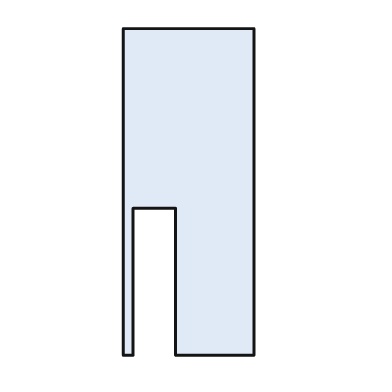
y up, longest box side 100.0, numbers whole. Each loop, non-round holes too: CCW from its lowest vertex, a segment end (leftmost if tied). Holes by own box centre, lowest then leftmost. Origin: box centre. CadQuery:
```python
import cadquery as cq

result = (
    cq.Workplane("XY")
    .moveTo(-20.0, -50.0)
    .lineTo(-17.0, -50.0)
    .lineTo(-17.0, -5.0)
    .lineTo(-4.0, -5.0)
    .lineTo(-4.0, -50.0)
    .lineTo(20.0, -50.0)
    .lineTo(20.0, 50.0)
    .lineTo(-20.0, 50.0)
    .close()
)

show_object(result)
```